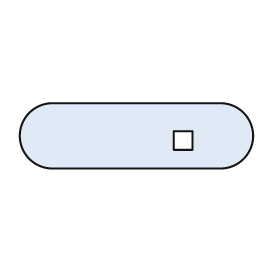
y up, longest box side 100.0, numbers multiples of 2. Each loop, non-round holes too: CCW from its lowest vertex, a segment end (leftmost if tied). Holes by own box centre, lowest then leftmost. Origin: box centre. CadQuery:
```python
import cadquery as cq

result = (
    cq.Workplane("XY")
    .moveTo(-36.0, -14.0)
    .lineTo(36.0, -14.0)
    .threePointArc((50.0, 0.0), (36.0, 14.0))
    .lineTo(-36.0, 14.0)
    .threePointArc((-50.0, 0.0), (-36.0, -14.0))
    .close()
    .moveTo(16.0, -6.0)
    .lineTo(24.0, -6.0)
    .lineTo(24.0, 2.0)
    .lineTo(16.0, 2.0)
    .close()
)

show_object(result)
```